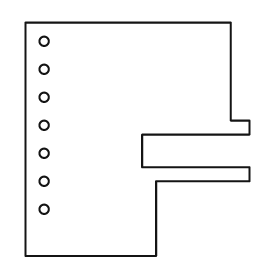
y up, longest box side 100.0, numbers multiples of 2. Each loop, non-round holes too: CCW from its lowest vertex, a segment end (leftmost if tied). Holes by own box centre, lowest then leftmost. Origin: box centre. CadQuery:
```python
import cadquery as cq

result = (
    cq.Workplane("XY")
    .moveTo(-48.0, -50.0)
    .lineTo(8.0, -50.0)
    .lineTo(8.0, -18.0)
    .lineTo(48.0, -18.0)
    .lineTo(48.0, -12.0)
    .lineTo(2.0, -12.0)
    .lineTo(2.0, 2.0)
    .lineTo(48.0, 2.0)
    .lineTo(48.0, 8.0)
    .lineTo(40.0, 8.0)
    .lineTo(40.0, 50.0)
    .lineTo(-48.0, 50.0)
    .close()
    .moveTo(-40.0, -30.0)
    .circle(2.0)
    .moveTo(-40.0, -18.0)
    .circle(2.0)
    .moveTo(-40.0, -6.0)
    .circle(2.0)
    .moveTo(-40.0, 6.0)
    .circle(2.0)
    .moveTo(-40.0, 18.0)
    .circle(2.0)
    .moveTo(-40.0, 30.0)
    .circle(2.0)
    .moveTo(-40.0, 42.0)
    .circle(2.0)
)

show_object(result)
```